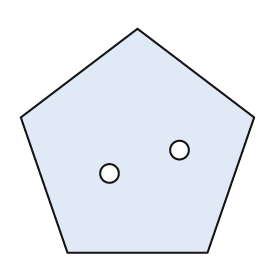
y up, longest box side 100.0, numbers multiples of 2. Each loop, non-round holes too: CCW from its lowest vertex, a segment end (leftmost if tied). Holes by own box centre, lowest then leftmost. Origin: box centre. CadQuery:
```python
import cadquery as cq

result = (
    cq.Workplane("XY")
    .moveTo(-30.0, -48.0)
    .lineTo(30.0, -48.0)
    .lineTo(50.0, 10.0)
    .lineTo(0.0, 48.0)
    .lineTo(-50.0, 10.0)
    .close()
    .moveTo(-12.0, -14.0)
    .circle(4.0)
    .moveTo(18.0, -4.0)
    .circle(4.0)
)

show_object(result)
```